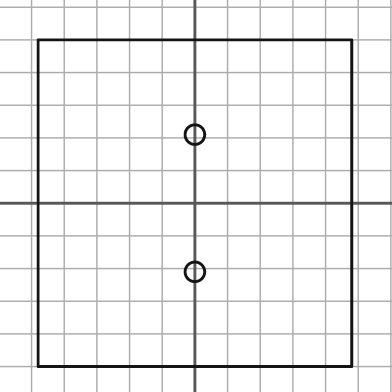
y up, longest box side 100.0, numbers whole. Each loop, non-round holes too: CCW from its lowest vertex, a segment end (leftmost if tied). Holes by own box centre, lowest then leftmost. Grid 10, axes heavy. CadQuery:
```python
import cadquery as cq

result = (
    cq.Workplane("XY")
    .moveTo(-48.0, -50.0)
    .lineTo(48.0, -50.0)
    .lineTo(48.0, 50.0)
    .lineTo(-48.0, 50.0)
    .close()
    .moveTo(0.0, -21.0)
    .circle(3.0)
    .moveTo(0.0, 21.0)
    .circle(3.0)
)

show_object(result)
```